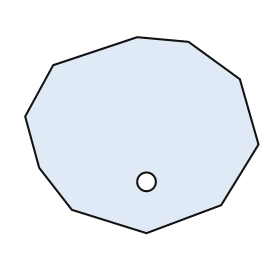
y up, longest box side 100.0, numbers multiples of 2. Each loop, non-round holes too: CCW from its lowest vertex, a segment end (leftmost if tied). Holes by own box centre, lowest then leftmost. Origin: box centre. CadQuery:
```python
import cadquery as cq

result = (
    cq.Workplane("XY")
    .moveTo(2.0, -42.0)
    .lineTo(34.0, -30.0)
    .lineTo(50.0, -4.0)
    .lineTo(42.0, 24.0)
    .lineTo(20.0, 40.0)
    .lineTo(-2.0, 42.0)
    .lineTo(-38.0, 30.0)
    .lineTo(-50.0, 8.0)
    .lineTo(-44.0, -14.0)
    .lineTo(-30.0, -32.0)
    .close()
    .moveTo(2.0, -20.0)
    .circle(4.0)
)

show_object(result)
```